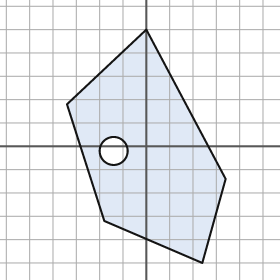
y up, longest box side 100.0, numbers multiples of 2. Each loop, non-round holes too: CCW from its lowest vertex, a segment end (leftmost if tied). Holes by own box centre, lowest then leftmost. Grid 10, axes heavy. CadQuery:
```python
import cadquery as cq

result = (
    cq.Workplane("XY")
    .moveTo(24.0, -50.0)
    .lineTo(34.0, -14.0)
    .lineTo(0.0, 50.0)
    .lineTo(-34.0, 18.0)
    .lineTo(-18.0, -32.0)
    .close()
    .moveTo(-14.0, -2.0)
    .circle(6.0)
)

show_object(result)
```